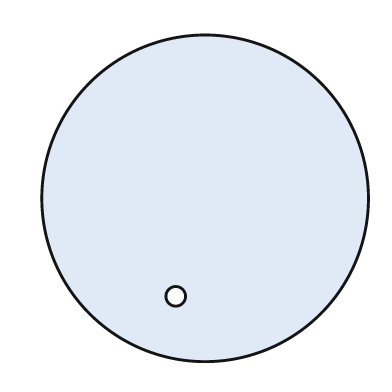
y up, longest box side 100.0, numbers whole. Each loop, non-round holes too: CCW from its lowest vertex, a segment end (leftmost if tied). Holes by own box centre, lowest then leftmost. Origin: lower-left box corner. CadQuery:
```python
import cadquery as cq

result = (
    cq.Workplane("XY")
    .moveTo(50.0, 50.0)
    .circle(50.0)
    .moveTo(41.0, 20.0)
    .circle(3.0)
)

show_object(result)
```